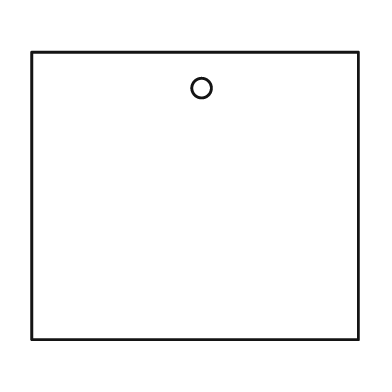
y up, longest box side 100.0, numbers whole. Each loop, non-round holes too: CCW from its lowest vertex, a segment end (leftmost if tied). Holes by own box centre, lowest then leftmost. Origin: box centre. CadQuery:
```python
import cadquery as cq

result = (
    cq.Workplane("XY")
    .moveTo(-50.0, -44.0)
    .lineTo(50.0, -44.0)
    .lineTo(50.0, 44.0)
    .lineTo(-50.0, 44.0)
    .close()
    .moveTo(2.0, 33.0)
    .circle(3.0)
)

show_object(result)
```